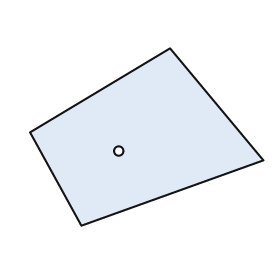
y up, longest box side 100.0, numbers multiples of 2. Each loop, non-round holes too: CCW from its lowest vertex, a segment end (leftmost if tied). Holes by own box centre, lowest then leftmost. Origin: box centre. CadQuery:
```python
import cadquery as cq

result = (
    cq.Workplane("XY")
    .moveTo(-28.0, -38.0)
    .lineTo(50.0, -10.0)
    .lineTo(10.0, 38.0)
    .lineTo(-50.0, 2.0)
    .close()
    .moveTo(-12.0, -6.0)
    .circle(2.0)
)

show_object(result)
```